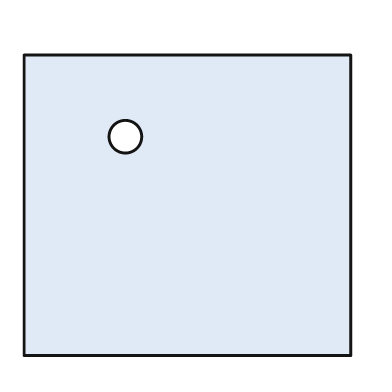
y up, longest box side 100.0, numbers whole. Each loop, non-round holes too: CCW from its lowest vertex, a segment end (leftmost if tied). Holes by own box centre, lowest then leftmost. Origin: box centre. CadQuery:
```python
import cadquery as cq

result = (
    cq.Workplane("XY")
    .moveTo(-50.0, -46.0)
    .lineTo(50.0, -46.0)
    .lineTo(50.0, 46.0)
    .lineTo(-50.0, 46.0)
    .close()
    .moveTo(-19.0, 21.0)
    .circle(5.0)
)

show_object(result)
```